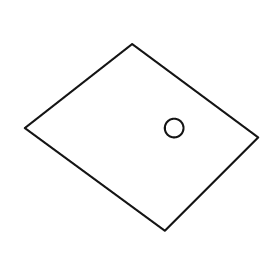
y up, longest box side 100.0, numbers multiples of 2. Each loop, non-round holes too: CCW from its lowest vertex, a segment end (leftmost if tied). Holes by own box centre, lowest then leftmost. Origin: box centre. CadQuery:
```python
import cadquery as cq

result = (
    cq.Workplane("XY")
    .moveTo(10.0, -40.0)
    .lineTo(50.0, 0.0)
    .lineTo(-4.0, 40.0)
    .lineTo(-50.0, 4.0)
    .close()
    .moveTo(14.0, 4.0)
    .circle(4.0)
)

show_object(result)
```